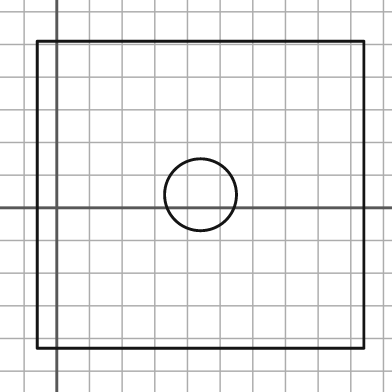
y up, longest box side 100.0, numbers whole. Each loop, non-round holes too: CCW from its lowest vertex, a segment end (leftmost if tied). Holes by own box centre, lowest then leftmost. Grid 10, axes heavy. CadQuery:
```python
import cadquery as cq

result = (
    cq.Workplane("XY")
    .moveTo(-6.0, -43.0)
    .lineTo(94.0, -43.0)
    .lineTo(94.0, 51.0)
    .lineTo(-6.0, 51.0)
    .close()
    .moveTo(44.0, 4.0)
    .circle(11.0)
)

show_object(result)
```